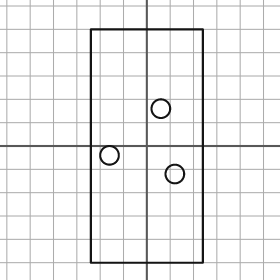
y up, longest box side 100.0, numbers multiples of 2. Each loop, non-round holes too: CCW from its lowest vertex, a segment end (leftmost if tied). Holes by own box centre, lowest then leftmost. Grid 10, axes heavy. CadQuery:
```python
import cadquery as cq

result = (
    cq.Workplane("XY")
    .moveTo(-24.0, -50.0)
    .lineTo(24.0, -50.0)
    .lineTo(24.0, 50.0)
    .lineTo(-24.0, 50.0)
    .close()
    .moveTo(12.0, -12.0)
    .circle(4.0)
    .moveTo(-16.0, -4.0)
    .circle(4.0)
    .moveTo(6.0, 16.0)
    .circle(4.0)
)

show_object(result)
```